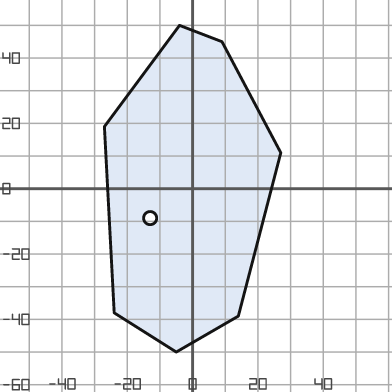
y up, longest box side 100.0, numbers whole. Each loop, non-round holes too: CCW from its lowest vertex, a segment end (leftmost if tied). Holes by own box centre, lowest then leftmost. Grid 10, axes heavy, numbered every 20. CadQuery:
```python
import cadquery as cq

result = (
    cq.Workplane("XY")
    .moveTo(-5.0, -50.0)
    .lineTo(14.0, -39.0)
    .lineTo(27.0, 11.0)
    .lineTo(9.0, 45.0)
    .lineTo(-4.0, 50.0)
    .lineTo(-27.0, 19.0)
    .lineTo(-24.0, -38.0)
    .close()
    .moveTo(-13.0, -9.0)
    .circle(2.0)
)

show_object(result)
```